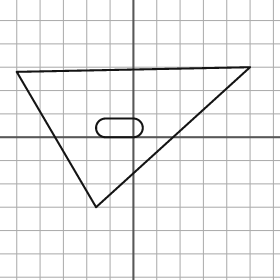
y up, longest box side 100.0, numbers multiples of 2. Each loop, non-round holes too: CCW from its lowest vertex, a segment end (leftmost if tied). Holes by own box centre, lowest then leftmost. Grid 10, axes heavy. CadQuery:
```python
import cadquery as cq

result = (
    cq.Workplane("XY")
    .moveTo(-16.0, -30.0)
    .lineTo(50.0, 30.0)
    .lineTo(-50.0, 28.0)
    .close()
    .moveTo(-12.0, 0.0)
    .lineTo(0.0, 0.0)
    .threePointArc((4.0, 4.0), (0.0, 8.0))
    .lineTo(-12.0, 8.0)
    .threePointArc((-16.0, 4.0), (-12.0, 0.0))
    .close()
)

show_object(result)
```